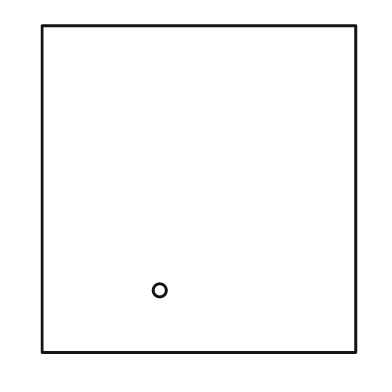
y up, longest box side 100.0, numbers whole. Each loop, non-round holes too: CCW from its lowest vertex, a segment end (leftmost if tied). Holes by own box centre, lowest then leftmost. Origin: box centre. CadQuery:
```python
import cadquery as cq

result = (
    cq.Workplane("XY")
    .moveTo(-48.0, -50.0)
    .lineTo(48.0, -50.0)
    .lineTo(48.0, 50.0)
    .lineTo(-48.0, 50.0)
    .close()
    .moveTo(-12.0, -31.0)
    .circle(2.0)
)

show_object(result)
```